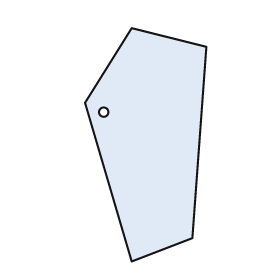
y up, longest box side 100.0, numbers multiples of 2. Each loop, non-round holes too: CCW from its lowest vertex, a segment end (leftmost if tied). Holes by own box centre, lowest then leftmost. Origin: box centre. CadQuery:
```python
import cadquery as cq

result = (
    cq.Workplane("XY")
    .moveTo(-6.0, -50.0)
    .lineTo(20.0, -40.0)
    .lineTo(26.0, 42.0)
    .lineTo(-6.0, 50.0)
    .lineTo(-26.0, 18.0)
    .close()
    .moveTo(-18.0, 14.0)
    .circle(2.0)
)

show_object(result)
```